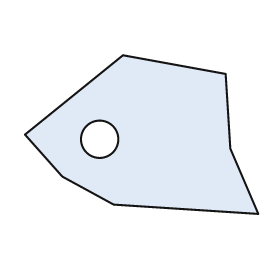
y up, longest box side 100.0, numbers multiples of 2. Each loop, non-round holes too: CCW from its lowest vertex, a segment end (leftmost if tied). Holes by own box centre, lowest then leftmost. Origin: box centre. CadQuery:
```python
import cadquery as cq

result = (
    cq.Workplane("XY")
    .moveTo(50.0, -34.0)
    .lineTo(38.0, -6.0)
    .lineTo(36.0, 26.0)
    .lineTo(-8.0, 34.0)
    .lineTo(-50.0, 0.0)
    .lineTo(-34.0, -18.0)
    .lineTo(-12.0, -30.0)
    .close()
    .moveTo(-18.0, -2.0)
    .circle(8.0)
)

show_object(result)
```